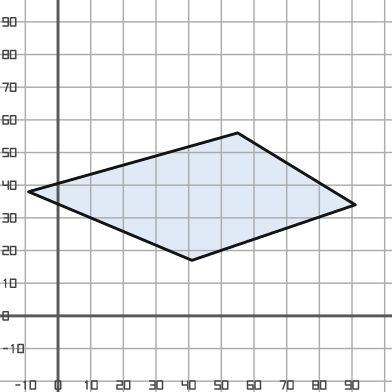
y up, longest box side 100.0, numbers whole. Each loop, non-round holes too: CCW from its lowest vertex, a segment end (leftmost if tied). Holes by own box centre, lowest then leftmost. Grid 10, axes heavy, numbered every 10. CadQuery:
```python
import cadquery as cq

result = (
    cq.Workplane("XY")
    .moveTo(41.0, 17.0)
    .lineTo(91.0, 34.0)
    .lineTo(55.0, 56.0)
    .lineTo(-9.0, 38.0)
    .close()
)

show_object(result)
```